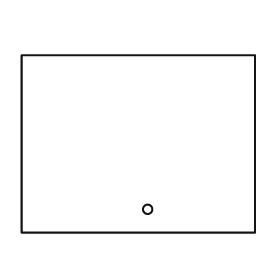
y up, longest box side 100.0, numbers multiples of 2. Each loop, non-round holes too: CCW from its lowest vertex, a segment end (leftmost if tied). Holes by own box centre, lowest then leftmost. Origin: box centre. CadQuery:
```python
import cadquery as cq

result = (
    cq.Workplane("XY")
    .moveTo(-50.0, -38.0)
    .lineTo(50.0, -38.0)
    .lineTo(50.0, 38.0)
    .lineTo(-50.0, 38.0)
    .close()
    .moveTo(4.0, -28.0)
    .circle(2.0)
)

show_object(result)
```